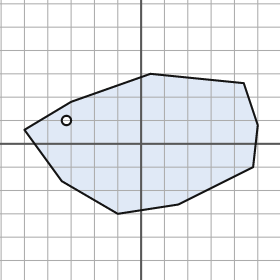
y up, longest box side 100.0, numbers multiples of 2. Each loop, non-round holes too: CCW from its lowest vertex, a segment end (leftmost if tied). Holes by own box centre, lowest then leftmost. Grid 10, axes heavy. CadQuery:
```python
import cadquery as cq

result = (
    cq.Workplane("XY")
    .moveTo(-10.0, -30.0)
    .lineTo(16.0, -26.0)
    .lineTo(48.0, -10.0)
    .lineTo(50.0, 8.0)
    .lineTo(44.0, 26.0)
    .lineTo(4.0, 30.0)
    .lineTo(-30.0, 18.0)
    .lineTo(-50.0, 6.0)
    .lineTo(-34.0, -16.0)
    .close()
    .moveTo(-32.0, 10.0)
    .circle(2.0)
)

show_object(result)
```